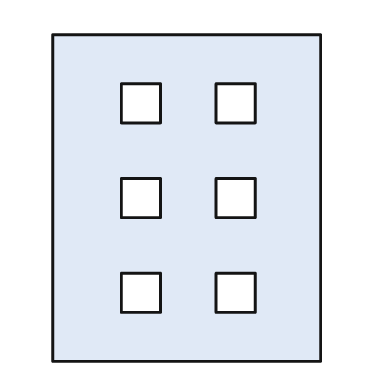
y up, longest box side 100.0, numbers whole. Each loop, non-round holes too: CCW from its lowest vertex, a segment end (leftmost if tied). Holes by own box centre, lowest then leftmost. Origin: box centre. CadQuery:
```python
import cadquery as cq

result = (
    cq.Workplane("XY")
    .moveTo(-41.0, -50.0)
    .lineTo(41.0, -50.0)
    .lineTo(41.0, 50.0)
    .lineTo(-41.0, 50.0)
    .close()
    .moveTo(-20.0, -35.0)
    .lineTo(-8.0, -35.0)
    .lineTo(-8.0, -23.0)
    .lineTo(-20.0, -23.0)
    .close()
    .moveTo(9.0, -35.0)
    .lineTo(21.0, -35.0)
    .lineTo(21.0, -23.0)
    .lineTo(9.0, -23.0)
    .close()
    .moveTo(-20.0, -6.0)
    .lineTo(-8.0, -6.0)
    .lineTo(-8.0, 6.0)
    .lineTo(-20.0, 6.0)
    .close()
    .moveTo(9.0, -6.0)
    .lineTo(21.0, -6.0)
    .lineTo(21.0, 6.0)
    .lineTo(9.0, 6.0)
    .close()
    .moveTo(-20.0, 23.0)
    .lineTo(-8.0, 23.0)
    .lineTo(-8.0, 35.0)
    .lineTo(-20.0, 35.0)
    .close()
    .moveTo(9.0, 23.0)
    .lineTo(21.0, 23.0)
    .lineTo(21.0, 35.0)
    .lineTo(9.0, 35.0)
    .close()
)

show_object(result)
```